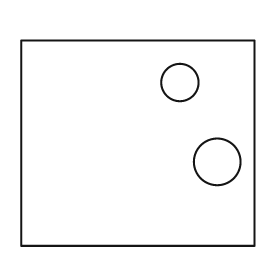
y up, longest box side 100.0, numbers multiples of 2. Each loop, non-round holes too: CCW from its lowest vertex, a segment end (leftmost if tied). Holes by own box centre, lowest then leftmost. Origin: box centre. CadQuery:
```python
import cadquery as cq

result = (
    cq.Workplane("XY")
    .moveTo(-50.0, -44.0)
    .lineTo(50.0, -44.0)
    .lineTo(50.0, 44.0)
    .lineTo(-50.0, 44.0)
    .close()
    .moveTo(34.0, -8.0)
    .circle(10.0)
    .moveTo(18.0, 26.0)
    .circle(8.0)
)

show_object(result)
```